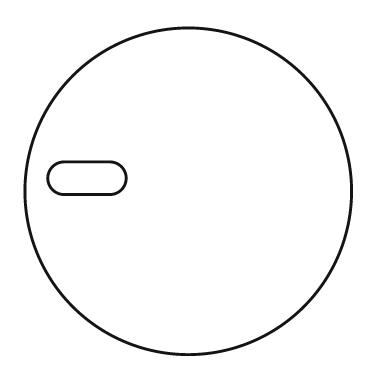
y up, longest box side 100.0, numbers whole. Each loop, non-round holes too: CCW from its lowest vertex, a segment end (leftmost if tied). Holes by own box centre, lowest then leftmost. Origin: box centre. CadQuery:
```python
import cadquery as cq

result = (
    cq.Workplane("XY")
    .moveTo(0.0, 0.0)
    .circle(50.0)
    .moveTo(-38.0, -1.0)
    .lineTo(-24.0, -1.0)
    .threePointArc((-19.0, 4.0), (-24.0, 9.0))
    .lineTo(-38.0, 9.0)
    .threePointArc((-43.0, 4.0), (-38.0, -1.0))
    .close()
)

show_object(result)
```